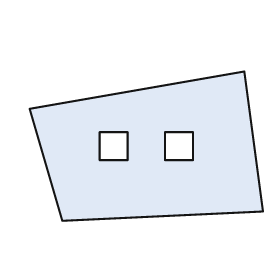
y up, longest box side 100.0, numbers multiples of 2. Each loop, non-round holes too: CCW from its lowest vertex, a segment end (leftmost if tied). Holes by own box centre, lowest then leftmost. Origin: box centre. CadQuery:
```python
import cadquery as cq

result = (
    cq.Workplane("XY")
    .moveTo(-36.0, -32.0)
    .lineTo(50.0, -28.0)
    .lineTo(42.0, 32.0)
    .lineTo(-50.0, 16.0)
    .close()
    .moveTo(-20.0, -6.0)
    .lineTo(-8.0, -6.0)
    .lineTo(-8.0, 6.0)
    .lineTo(-20.0, 6.0)
    .close()
    .moveTo(8.0, -6.0)
    .lineTo(20.0, -6.0)
    .lineTo(20.0, 6.0)
    .lineTo(8.0, 6.0)
    .close()
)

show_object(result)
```